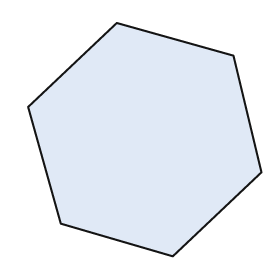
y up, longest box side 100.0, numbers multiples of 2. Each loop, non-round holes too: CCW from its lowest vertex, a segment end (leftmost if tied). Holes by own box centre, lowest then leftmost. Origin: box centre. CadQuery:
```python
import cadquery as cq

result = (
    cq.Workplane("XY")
    .moveTo(12.0, -50.0)
    .lineTo(50.0, -14.0)
    .lineTo(38.0, 36.0)
    .lineTo(-12.0, 50.0)
    .lineTo(-50.0, 14.0)
    .lineTo(-36.0, -36.0)
    .close()
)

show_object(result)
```